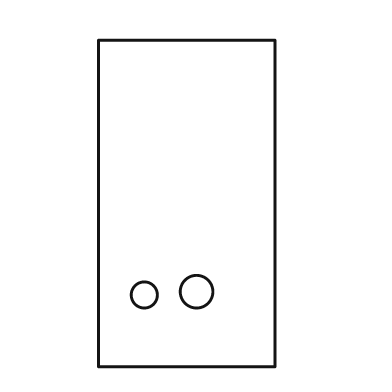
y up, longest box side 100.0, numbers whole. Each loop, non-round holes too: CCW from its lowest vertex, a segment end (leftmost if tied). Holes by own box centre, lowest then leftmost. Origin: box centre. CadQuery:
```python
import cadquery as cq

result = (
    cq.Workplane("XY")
    .moveTo(-27.0, -50.0)
    .lineTo(27.0, -50.0)
    .lineTo(27.0, 50.0)
    .lineTo(-27.0, 50.0)
    .close()
    .moveTo(-13.0, -28.0)
    .circle(4.0)
    .moveTo(3.0, -27.0)
    .circle(5.0)
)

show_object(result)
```